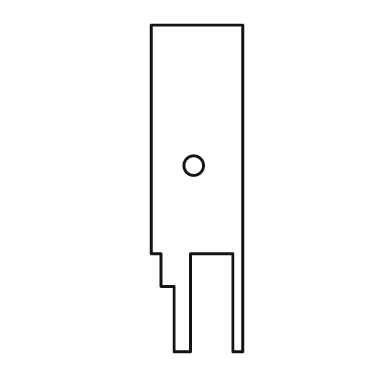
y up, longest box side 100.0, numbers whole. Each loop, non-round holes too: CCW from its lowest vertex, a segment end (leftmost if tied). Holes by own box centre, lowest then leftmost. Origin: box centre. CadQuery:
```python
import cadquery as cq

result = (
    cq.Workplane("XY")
    .moveTo(-7.0, -50.0)
    .lineTo(-2.0, -50.0)
    .lineTo(-2.0, -20.0)
    .lineTo(11.0, -20.0)
    .lineTo(11.0, -50.0)
    .lineTo(14.0, -50.0)
    .lineTo(14.0, 50.0)
    .lineTo(-14.0, 50.0)
    .lineTo(-14.0, -20.0)
    .lineTo(-11.0, -20.0)
    .lineTo(-11.0, -30.0)
    .lineTo(-7.0, -30.0)
    .close()
    .moveTo(-1.0, 7.0)
    .circle(3.0)
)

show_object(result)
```